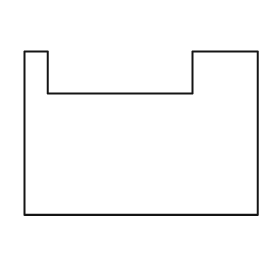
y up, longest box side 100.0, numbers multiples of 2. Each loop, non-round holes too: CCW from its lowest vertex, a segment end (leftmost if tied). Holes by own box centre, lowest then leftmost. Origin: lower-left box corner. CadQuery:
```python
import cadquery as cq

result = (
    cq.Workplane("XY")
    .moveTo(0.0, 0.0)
    .lineTo(100.0, 0.0)
    .lineTo(100.0, 70.0)
    .lineTo(72.0, 70.0)
    .lineTo(72.0, 52.0)
    .lineTo(10.0, 52.0)
    .lineTo(10.0, 70.0)
    .lineTo(0.0, 70.0)
    .close()
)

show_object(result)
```